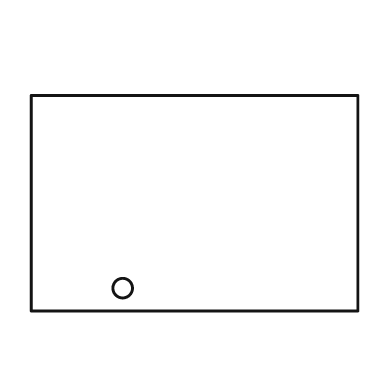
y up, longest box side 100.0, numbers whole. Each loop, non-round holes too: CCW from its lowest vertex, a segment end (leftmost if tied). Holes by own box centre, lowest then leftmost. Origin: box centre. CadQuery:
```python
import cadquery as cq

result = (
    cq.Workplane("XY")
    .moveTo(-50.0, -33.0)
    .lineTo(50.0, -33.0)
    .lineTo(50.0, 33.0)
    .lineTo(-50.0, 33.0)
    .close()
    .moveTo(-22.0, -26.0)
    .circle(3.0)
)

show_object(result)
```